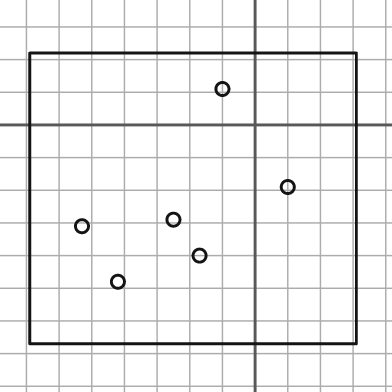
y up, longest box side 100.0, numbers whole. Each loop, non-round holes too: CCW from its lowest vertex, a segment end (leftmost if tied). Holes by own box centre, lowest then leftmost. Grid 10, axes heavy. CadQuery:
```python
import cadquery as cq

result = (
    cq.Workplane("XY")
    .moveTo(-69.0, -67.0)
    .lineTo(31.0, -67.0)
    .lineTo(31.0, 22.0)
    .lineTo(-69.0, 22.0)
    .close()
    .moveTo(-42.0, -48.0)
    .circle(2.0)
    .moveTo(-17.0, -40.0)
    .circle(2.0)
    .moveTo(-53.0, -31.0)
    .circle(2.0)
    .moveTo(-25.0, -29.0)
    .circle(2.0)
    .moveTo(10.0, -19.0)
    .circle(2.0)
    .moveTo(-10.0, 11.0)
    .circle(2.0)
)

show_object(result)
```